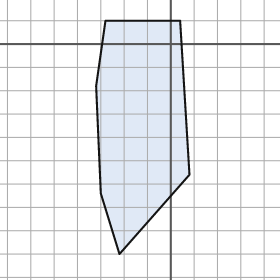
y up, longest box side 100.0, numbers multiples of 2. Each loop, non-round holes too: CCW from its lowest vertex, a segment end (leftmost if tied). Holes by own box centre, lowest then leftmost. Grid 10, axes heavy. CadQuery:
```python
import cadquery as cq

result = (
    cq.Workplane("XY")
    .moveTo(-22.0, -90.0)
    .lineTo(8.0, -56.0)
    .lineTo(4.0, 10.0)
    .lineTo(-28.0, 10.0)
    .lineTo(-32.0, -18.0)
    .lineTo(-30.0, -64.0)
    .close()
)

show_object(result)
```